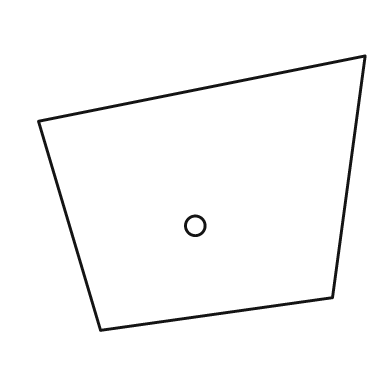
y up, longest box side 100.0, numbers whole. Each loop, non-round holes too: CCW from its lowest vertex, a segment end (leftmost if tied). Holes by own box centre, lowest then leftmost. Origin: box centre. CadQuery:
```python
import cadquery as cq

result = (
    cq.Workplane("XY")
    .moveTo(-31.0, -42.0)
    .lineTo(40.0, -32.0)
    .lineTo(50.0, 42.0)
    .lineTo(-50.0, 22.0)
    .close()
    .moveTo(-2.0, -10.0)
    .circle(3.0)
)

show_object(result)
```